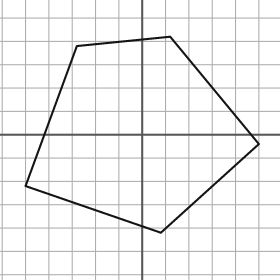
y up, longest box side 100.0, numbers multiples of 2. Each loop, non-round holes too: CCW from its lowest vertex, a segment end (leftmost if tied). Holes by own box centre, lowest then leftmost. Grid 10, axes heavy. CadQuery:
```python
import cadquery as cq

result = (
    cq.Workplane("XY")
    .moveTo(8.0, -42.0)
    .lineTo(50.0, -4.0)
    .lineTo(12.0, 42.0)
    .lineTo(-28.0, 38.0)
    .lineTo(-50.0, -22.0)
    .close()
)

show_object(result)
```